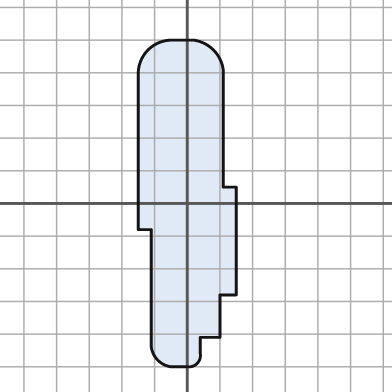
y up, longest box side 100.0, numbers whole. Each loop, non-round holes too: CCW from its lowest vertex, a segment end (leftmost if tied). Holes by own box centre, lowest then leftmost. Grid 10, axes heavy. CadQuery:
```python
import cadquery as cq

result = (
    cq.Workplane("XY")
    .moveTo(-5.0, -50.0)
    .lineTo(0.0, -50.0)
    .threePointArc((3.0, -49.0), (4.0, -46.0))
    .lineTo(4.0, -41.0)
    .lineTo(10.0, -41.0)
    .lineTo(10.0, -28.0)
    .lineTo(15.0, -28.0)
    .lineTo(15.0, 5.0)
    .lineTo(11.0, 5.0)
    .lineTo(11.0, 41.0)
    .threePointArc((8.0, 47.0), (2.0, 50.0))
    .lineTo(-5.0, 50.0)
    .threePointArc((-12.0, 47.0), (-15.0, 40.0))
    .lineTo(-15.0, -8.0)
    .lineTo(-11.0, -8.0)
    .lineTo(-11.0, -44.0)
    .threePointArc((-9.0, -48.0), (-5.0, -50.0))
    .close()
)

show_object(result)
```